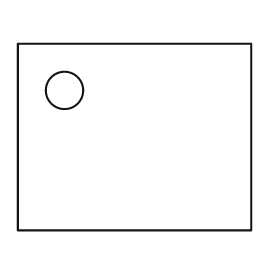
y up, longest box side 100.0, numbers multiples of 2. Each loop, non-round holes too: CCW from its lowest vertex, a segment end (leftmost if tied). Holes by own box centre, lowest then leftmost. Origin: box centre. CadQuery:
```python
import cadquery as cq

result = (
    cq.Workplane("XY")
    .moveTo(-50.0, -40.0)
    .lineTo(50.0, -40.0)
    .lineTo(50.0, 40.0)
    .lineTo(-50.0, 40.0)
    .close()
    .moveTo(-30.0, 20.0)
    .circle(8.0)
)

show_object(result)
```